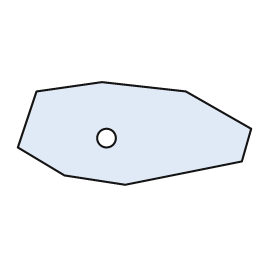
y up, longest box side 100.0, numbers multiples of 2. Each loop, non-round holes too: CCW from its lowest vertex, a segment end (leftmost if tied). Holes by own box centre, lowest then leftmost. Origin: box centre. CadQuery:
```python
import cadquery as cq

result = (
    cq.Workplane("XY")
    .moveTo(-4.0, -22.0)
    .lineTo(46.0, -12.0)
    .lineTo(50.0, 2.0)
    .lineTo(22.0, 18.0)
    .lineTo(-14.0, 22.0)
    .lineTo(-42.0, 18.0)
    .lineTo(-50.0, -6.0)
    .lineTo(-30.0, -18.0)
    .close()
    .moveTo(-12.0, -2.0)
    .circle(4.0)
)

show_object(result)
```